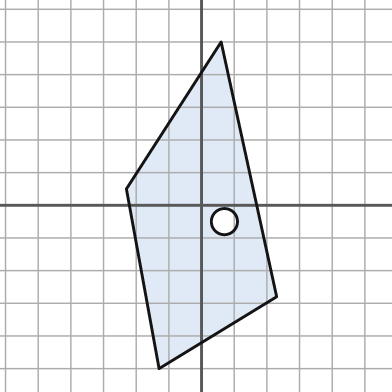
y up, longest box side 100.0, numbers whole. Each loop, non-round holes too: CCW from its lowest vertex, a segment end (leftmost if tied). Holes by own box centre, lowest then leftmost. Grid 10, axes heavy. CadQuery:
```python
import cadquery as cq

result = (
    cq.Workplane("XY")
    .moveTo(-13.0, -50.0)
    .lineTo(23.0, -28.0)
    .lineTo(6.0, 50.0)
    .lineTo(-23.0, 5.0)
    .close()
    .moveTo(7.0, -5.0)
    .circle(4.0)
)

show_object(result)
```